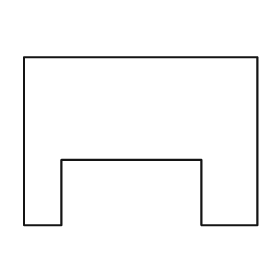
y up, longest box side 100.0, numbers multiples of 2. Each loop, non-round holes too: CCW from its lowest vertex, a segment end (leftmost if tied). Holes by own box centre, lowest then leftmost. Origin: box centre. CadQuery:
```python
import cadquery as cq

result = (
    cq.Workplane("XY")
    .moveTo(-50.0, -36.0)
    .lineTo(-34.0, -36.0)
    .lineTo(-34.0, -8.0)
    .lineTo(26.0, -8.0)
    .lineTo(26.0, -36.0)
    .lineTo(50.0, -36.0)
    .lineTo(50.0, 36.0)
    .lineTo(-50.0, 36.0)
    .close()
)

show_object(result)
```